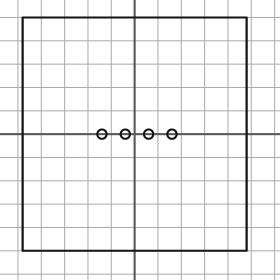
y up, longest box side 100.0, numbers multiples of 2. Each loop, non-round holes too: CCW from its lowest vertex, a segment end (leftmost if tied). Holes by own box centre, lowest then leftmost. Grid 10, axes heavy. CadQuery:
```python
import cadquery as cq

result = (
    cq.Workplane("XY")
    .moveTo(-48.0, -50.0)
    .lineTo(48.0, -50.0)
    .lineTo(48.0, 50.0)
    .lineTo(-48.0, 50.0)
    .close()
    .moveTo(-14.0, 0.0)
    .circle(2.0)
    .moveTo(-4.0, 0.0)
    .circle(2.0)
    .moveTo(6.0, 0.0)
    .circle(2.0)
    .moveTo(16.0, 0.0)
    .circle(2.0)
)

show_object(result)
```